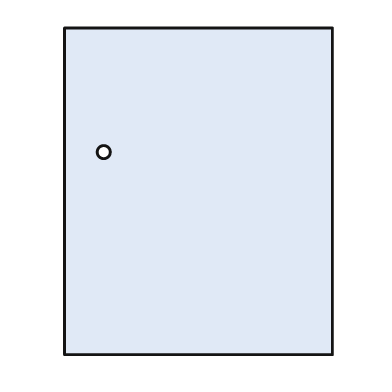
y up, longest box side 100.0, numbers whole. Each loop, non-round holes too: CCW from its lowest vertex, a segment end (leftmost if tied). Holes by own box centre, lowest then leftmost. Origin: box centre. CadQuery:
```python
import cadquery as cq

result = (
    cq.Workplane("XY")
    .moveTo(-41.0, -50.0)
    .lineTo(41.0, -50.0)
    .lineTo(41.0, 50.0)
    .lineTo(-41.0, 50.0)
    .close()
    .moveTo(-29.0, 12.0)
    .circle(2.0)
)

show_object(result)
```